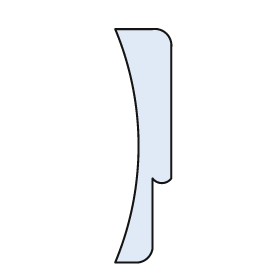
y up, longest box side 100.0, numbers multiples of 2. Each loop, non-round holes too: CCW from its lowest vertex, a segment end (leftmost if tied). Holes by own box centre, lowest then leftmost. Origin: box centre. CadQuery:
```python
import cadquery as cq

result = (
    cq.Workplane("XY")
    .moveTo(-12.0, -50.0)
    .lineTo(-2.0, -50.0)
    .threePointArc((2.0, -48.0), (4.0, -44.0))
    .lineTo(4.0, -14.0)
    .threePointArc((8.0, -16.0), (12.0, -14.0))
    .lineTo(12.0, 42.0)
    .threePointArc((10.0, 48.0), (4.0, 50.0))
    .lineTo(-12.0, 50.0)
    .threePointArc((-2.0, 0.0), (-12.0, -50.0))
    .close()
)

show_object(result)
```